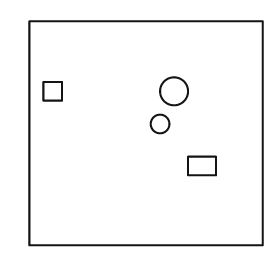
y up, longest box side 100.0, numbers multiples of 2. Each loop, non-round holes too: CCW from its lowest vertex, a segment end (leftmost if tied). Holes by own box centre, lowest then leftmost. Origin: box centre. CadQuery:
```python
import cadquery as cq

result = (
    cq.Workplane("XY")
    .moveTo(-50.0, -48.0)
    .lineTo(50.0, -48.0)
    .lineTo(50.0, 48.0)
    .lineTo(-50.0, 48.0)
    .close()
    .moveTo(18.0, -18.0)
    .lineTo(30.0, -18.0)
    .lineTo(30.0, -10.0)
    .lineTo(18.0, -10.0)
    .close()
    .moveTo(6.0, 4.0)
    .circle(4.0)
    .moveTo(-44.0, 14.0)
    .lineTo(-36.0, 14.0)
    .lineTo(-36.0, 22.0)
    .lineTo(-44.0, 22.0)
    .close()
    .moveTo(12.0, 18.0)
    .circle(6.0)
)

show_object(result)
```